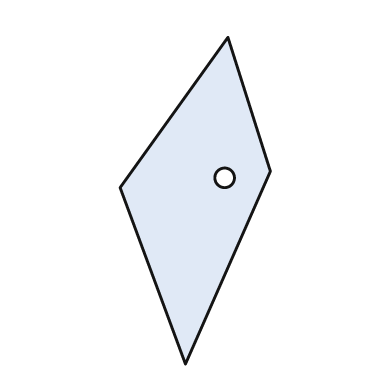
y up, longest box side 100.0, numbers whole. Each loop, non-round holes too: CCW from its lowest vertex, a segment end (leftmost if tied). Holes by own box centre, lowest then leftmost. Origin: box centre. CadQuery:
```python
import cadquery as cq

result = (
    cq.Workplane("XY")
    .moveTo(-3.0, -50.0)
    .lineTo(23.0, 9.0)
    .lineTo(10.0, 50.0)
    .lineTo(-23.0, 4.0)
    .close()
    .moveTo(9.0, 7.0)
    .circle(3.0)
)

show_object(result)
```